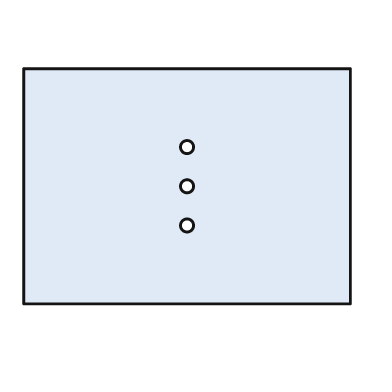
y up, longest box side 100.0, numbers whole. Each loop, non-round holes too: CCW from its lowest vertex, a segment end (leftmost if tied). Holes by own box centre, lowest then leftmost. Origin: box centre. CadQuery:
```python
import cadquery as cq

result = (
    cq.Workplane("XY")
    .moveTo(-50.0, -36.0)
    .lineTo(50.0, -36.0)
    .lineTo(50.0, 36.0)
    .lineTo(-50.0, 36.0)
    .close()
    .moveTo(0.0, -12.0)
    .circle(2.0)
    .moveTo(0.0, 0.0)
    .circle(2.0)
    .moveTo(0.0, 12.0)
    .circle(2.0)
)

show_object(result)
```